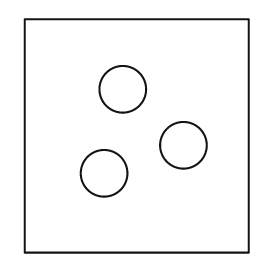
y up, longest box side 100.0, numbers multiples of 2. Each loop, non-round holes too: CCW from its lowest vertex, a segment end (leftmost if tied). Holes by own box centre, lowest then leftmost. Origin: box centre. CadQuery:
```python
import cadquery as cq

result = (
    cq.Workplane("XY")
    .moveTo(-48.0, -50.0)
    .lineTo(48.0, -50.0)
    .lineTo(48.0, 50.0)
    .lineTo(-48.0, 50.0)
    .close()
    .moveTo(-14.0, -16.0)
    .circle(10.0)
    .moveTo(20.0, -4.0)
    .circle(10.0)
    .moveTo(-6.0, 20.0)
    .circle(10.0)
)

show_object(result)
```